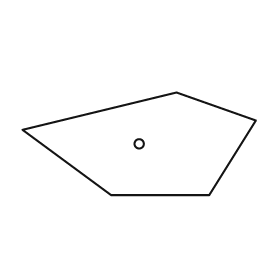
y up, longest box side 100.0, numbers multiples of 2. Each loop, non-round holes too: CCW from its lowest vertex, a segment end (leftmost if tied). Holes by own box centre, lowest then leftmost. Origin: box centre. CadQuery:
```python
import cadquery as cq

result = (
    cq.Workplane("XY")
    .moveTo(-12.0, -22.0)
    .lineTo(30.0, -22.0)
    .lineTo(50.0, 10.0)
    .lineTo(16.0, 22.0)
    .lineTo(-50.0, 6.0)
    .close()
    .moveTo(0.0, 0.0)
    .circle(2.0)
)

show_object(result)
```